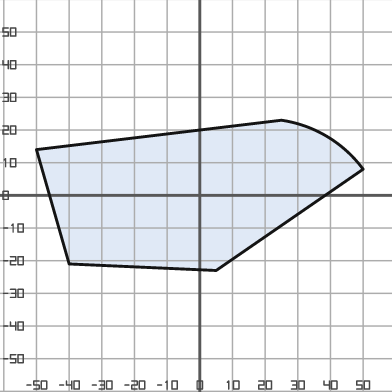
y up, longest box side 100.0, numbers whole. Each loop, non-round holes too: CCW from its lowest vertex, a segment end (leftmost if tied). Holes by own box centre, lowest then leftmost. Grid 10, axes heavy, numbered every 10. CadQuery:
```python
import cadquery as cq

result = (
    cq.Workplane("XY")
    .moveTo(5.0, -23.0)
    .lineTo(50.0, 8.0)
    .threePointArc((39.0, 18.0), (25.0, 23.0))
    .lineTo(-50.0, 14.0)
    .lineTo(-40.0, -21.0)
    .close()
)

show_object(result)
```